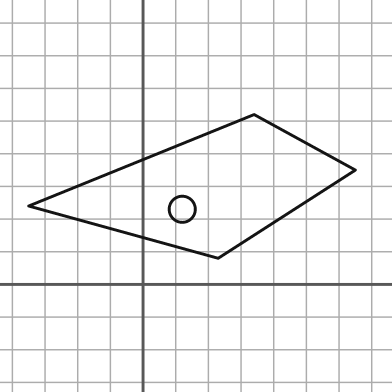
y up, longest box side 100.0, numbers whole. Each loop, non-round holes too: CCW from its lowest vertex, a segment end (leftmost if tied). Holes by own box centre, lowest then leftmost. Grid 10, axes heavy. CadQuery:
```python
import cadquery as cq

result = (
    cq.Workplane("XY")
    .moveTo(23.0, 8.0)
    .lineTo(65.0, 35.0)
    .lineTo(34.0, 52.0)
    .lineTo(-35.0, 24.0)
    .close()
    .moveTo(12.0, 23.0)
    .circle(4.0)
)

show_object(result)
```